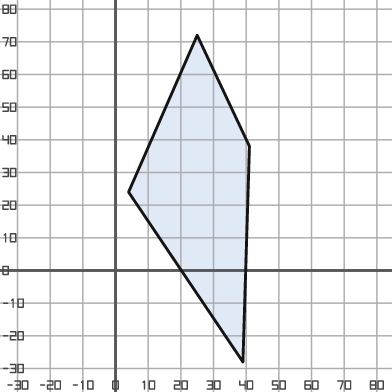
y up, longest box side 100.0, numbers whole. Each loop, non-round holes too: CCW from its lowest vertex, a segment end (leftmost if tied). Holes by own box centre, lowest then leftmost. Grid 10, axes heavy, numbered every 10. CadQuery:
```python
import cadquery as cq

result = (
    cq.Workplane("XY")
    .moveTo(39.0, -28.0)
    .lineTo(41.0, 38.0)
    .lineTo(25.0, 72.0)
    .lineTo(4.0, 24.0)
    .close()
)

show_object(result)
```